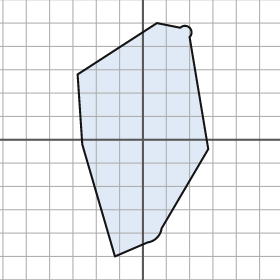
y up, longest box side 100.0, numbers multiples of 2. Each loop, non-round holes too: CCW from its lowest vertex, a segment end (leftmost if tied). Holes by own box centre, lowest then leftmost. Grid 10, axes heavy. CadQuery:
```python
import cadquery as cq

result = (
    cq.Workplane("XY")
    .moveTo(-12.0, -50.0)
    .lineTo(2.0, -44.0)
    .threePointArc((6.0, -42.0), (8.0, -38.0))
    .lineTo(28.0, -4.0)
    .lineTo(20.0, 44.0)
    .threePointArc((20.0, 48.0), (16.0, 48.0))
    .lineTo(6.0, 50.0)
    .lineTo(-28.0, 28.0)
    .lineTo(-26.0, -2.0)
    .close()
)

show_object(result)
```